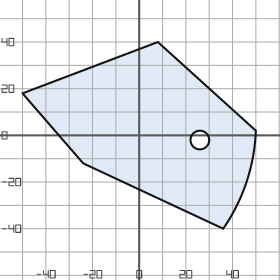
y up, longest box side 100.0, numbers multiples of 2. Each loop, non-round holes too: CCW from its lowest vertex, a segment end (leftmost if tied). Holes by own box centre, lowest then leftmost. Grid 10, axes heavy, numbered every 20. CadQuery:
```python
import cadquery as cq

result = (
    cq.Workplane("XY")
    .moveTo(36.0, -40.0)
    .threePointArc((46.0, -20.0), (50.0, 2.0))
    .lineTo(8.0, 40.0)
    .lineTo(-50.0, 18.0)
    .lineTo(-24.0, -12.0)
    .close()
    .moveTo(26.0, -2.0)
    .circle(4.0)
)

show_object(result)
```